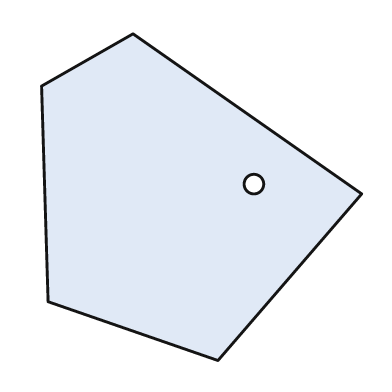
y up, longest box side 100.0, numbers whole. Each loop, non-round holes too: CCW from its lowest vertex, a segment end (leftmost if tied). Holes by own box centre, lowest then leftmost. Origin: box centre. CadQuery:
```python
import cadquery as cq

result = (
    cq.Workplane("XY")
    .moveTo(5.0, -50.0)
    .lineTo(49.0, 1.0)
    .lineTo(-21.0, 50.0)
    .lineTo(-49.0, 34.0)
    .lineTo(-47.0, -32.0)
    .close()
    .moveTo(16.0, 4.0)
    .circle(3.0)
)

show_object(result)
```